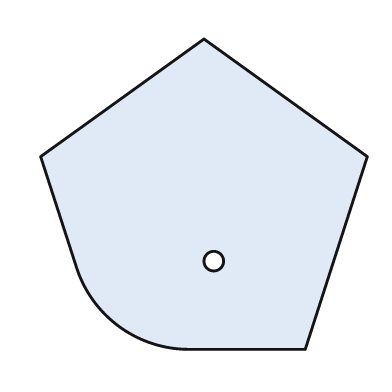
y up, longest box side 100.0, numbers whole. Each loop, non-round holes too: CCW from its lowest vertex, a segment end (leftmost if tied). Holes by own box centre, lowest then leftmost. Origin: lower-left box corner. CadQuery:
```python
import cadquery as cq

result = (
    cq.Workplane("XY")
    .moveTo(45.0, 0.0)
    .lineTo(81.0, 0.0)
    .lineTo(100.0, 59.0)
    .lineTo(50.0, 95.0)
    .lineTo(0.0, 59.0)
    .lineTo(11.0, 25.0)
    .threePointArc((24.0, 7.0), (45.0, 0.0))
    .close()
    .moveTo(53.0, 27.0)
    .circle(3.0)
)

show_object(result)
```